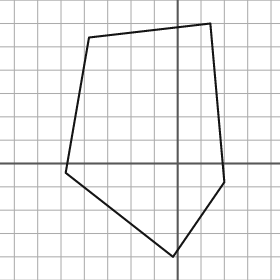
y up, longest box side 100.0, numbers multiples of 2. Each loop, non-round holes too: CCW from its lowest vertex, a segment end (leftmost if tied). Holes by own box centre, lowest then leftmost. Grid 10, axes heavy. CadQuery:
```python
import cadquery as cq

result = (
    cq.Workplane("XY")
    .moveTo(-2.0, -40.0)
    .lineTo(20.0, -8.0)
    .lineTo(14.0, 60.0)
    .lineTo(-38.0, 54.0)
    .lineTo(-48.0, -4.0)
    .close()
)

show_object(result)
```